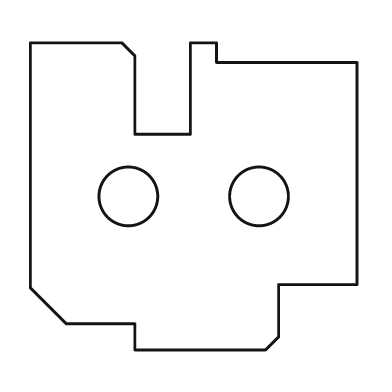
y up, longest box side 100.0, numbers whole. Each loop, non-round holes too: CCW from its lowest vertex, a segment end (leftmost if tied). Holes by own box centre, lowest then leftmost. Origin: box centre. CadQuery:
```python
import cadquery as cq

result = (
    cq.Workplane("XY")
    .moveTo(-18.0, -47.0)
    .lineTo(22.0, -47.0)
    .lineTo(26.0, -43.0)
    .lineTo(26.0, -27.0)
    .lineTo(50.0, -27.0)
    .lineTo(50.0, 41.0)
    .lineTo(7.0, 41.0)
    .lineTo(7.0, 47.0)
    .lineTo(-1.0, 47.0)
    .lineTo(-1.0, 19.0)
    .lineTo(-18.0, 19.0)
    .lineTo(-18.0, 43.0)
    .lineTo(-22.0, 47.0)
    .lineTo(-50.0, 47.0)
    .lineTo(-50.0, -28.0)
    .lineTo(-39.0, -39.0)
    .lineTo(-18.0, -39.0)
    .close()
    .moveTo(-20.0, 0.0)
    .circle(9.0)
    .moveTo(20.0, 0.0)
    .circle(9.0)
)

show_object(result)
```